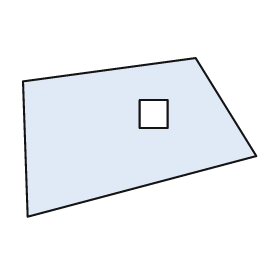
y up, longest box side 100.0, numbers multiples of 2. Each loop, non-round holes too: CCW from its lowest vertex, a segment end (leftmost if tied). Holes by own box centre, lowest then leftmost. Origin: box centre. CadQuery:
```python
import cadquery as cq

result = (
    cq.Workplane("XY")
    .moveTo(-48.0, -34.0)
    .lineTo(50.0, -8.0)
    .lineTo(24.0, 34.0)
    .lineTo(-50.0, 24.0)
    .close()
    .moveTo(0.0, 4.0)
    .lineTo(12.0, 4.0)
    .lineTo(12.0, 16.0)
    .lineTo(0.0, 16.0)
    .close()
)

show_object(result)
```